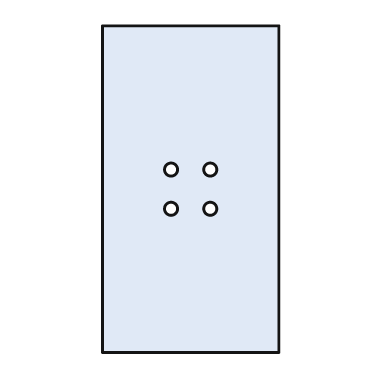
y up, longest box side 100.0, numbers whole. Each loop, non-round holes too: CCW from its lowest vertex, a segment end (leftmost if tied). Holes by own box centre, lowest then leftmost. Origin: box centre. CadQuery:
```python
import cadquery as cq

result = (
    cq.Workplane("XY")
    .moveTo(-27.0, -50.0)
    .lineTo(27.0, -50.0)
    .lineTo(27.0, 50.0)
    .lineTo(-27.0, 50.0)
    .close()
    .moveTo(-6.0, -6.0)
    .circle(2.0)
    .moveTo(6.0, -6.0)
    .circle(2.0)
    .moveTo(-6.0, 6.0)
    .circle(2.0)
    .moveTo(6.0, 6.0)
    .circle(2.0)
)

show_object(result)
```